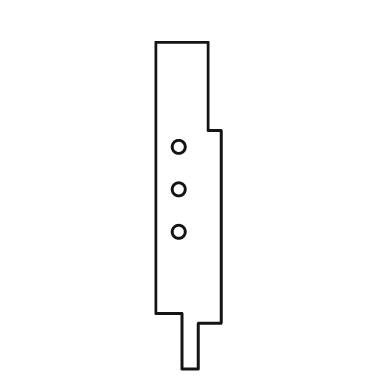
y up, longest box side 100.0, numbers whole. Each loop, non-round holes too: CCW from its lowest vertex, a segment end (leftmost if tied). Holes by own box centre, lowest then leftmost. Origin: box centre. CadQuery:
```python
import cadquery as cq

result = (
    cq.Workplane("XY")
    .moveTo(-2.0, -50.0)
    .lineTo(3.0, -50.0)
    .lineTo(3.0, -36.0)
    .lineTo(10.0, -36.0)
    .lineTo(10.0, 23.0)
    .lineTo(6.0, 23.0)
    .lineTo(6.0, 50.0)
    .lineTo(-10.0, 50.0)
    .lineTo(-10.0, -33.0)
    .lineTo(-2.0, -33.0)
    .close()
    .moveTo(-3.0, -8.0)
    .circle(2.0)
    .moveTo(-3.0, 5.0)
    .circle(2.0)
    .moveTo(-3.0, 18.0)
    .circle(2.0)
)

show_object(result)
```